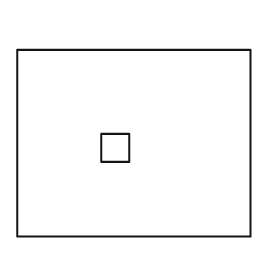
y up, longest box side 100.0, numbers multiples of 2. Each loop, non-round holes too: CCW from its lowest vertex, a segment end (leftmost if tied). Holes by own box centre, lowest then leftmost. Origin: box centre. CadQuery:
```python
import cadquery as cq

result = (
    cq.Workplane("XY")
    .moveTo(-50.0, -40.0)
    .lineTo(50.0, -40.0)
    .lineTo(50.0, 40.0)
    .lineTo(-50.0, 40.0)
    .close()
    .moveTo(-14.0, -8.0)
    .lineTo(-2.0, -8.0)
    .lineTo(-2.0, 4.0)
    .lineTo(-14.0, 4.0)
    .close()
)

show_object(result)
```